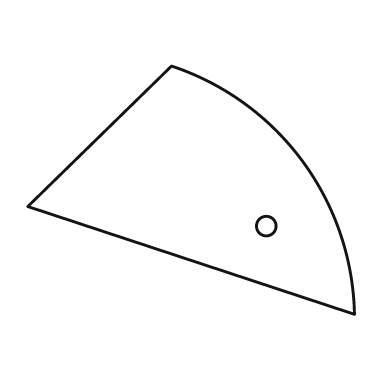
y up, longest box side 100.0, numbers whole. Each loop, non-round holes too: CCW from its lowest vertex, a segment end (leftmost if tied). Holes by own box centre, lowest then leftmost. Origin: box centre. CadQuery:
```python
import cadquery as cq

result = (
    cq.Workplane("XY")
    .moveTo(50.0, -38.0)
    .threePointArc((34.0, 9.0), (-6.0, 38.0))
    .lineTo(-50.0, -5.0)
    .close()
    .moveTo(23.0, -11.0)
    .circle(3.0)
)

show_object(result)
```